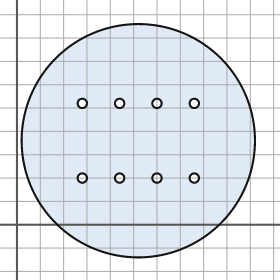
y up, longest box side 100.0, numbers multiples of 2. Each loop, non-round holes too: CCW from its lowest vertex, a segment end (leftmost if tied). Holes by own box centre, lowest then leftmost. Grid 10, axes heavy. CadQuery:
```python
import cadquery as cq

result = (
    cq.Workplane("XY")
    .moveTo(52.0, 36.0)
    .circle(50.0)
    .moveTo(28.0, 20.0)
    .circle(2.0)
    .moveTo(44.0, 20.0)
    .circle(2.0)
    .moveTo(60.0, 20.0)
    .circle(2.0)
    .moveTo(76.0, 20.0)
    .circle(2.0)
    .moveTo(28.0, 52.0)
    .circle(2.0)
    .moveTo(44.0, 52.0)
    .circle(2.0)
    .moveTo(60.0, 52.0)
    .circle(2.0)
    .moveTo(76.0, 52.0)
    .circle(2.0)
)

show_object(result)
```